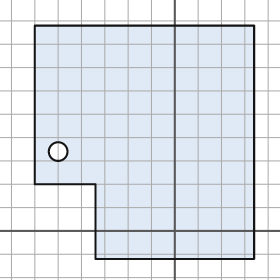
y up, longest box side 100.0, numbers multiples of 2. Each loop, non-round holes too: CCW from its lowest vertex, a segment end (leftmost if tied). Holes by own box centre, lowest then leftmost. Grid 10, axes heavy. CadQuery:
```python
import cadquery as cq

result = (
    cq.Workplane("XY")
    .moveTo(-34.0, -12.0)
    .lineTo(34.0, -12.0)
    .lineTo(34.0, 88.0)
    .lineTo(-60.0, 88.0)
    .lineTo(-60.0, 20.0)
    .lineTo(-34.0, 20.0)
    .close()
    .moveTo(-50.0, 34.0)
    .circle(4.0)
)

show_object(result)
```